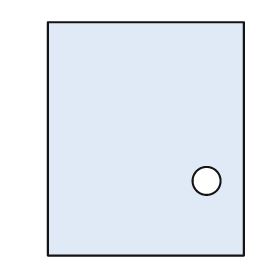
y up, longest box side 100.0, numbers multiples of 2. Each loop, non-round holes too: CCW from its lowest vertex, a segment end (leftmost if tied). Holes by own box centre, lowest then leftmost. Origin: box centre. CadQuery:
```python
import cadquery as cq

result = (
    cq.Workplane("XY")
    .moveTo(-42.0, -50.0)
    .lineTo(42.0, -50.0)
    .lineTo(42.0, 50.0)
    .lineTo(-42.0, 50.0)
    .close()
    .moveTo(26.0, -18.0)
    .circle(6.0)
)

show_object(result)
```